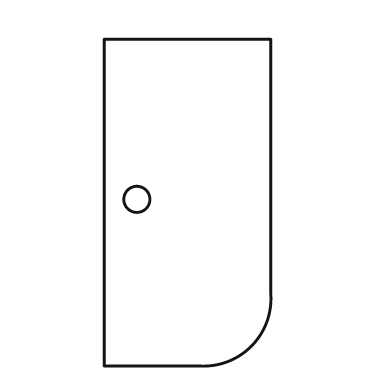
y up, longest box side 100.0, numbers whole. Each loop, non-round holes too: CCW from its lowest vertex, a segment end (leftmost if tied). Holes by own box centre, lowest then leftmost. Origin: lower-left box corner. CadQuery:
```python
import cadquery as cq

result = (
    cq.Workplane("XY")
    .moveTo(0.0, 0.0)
    .lineTo(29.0, 0.0)
    .threePointArc((45.0, 6.0), (51.0, 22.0))
    .lineTo(51.0, 100.0)
    .lineTo(0.0, 100.0)
    .close()
    .moveTo(10.0, 51.0)
    .circle(4.0)
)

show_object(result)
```